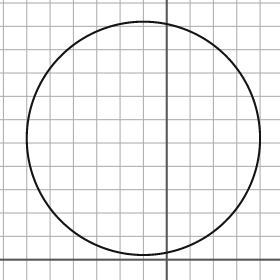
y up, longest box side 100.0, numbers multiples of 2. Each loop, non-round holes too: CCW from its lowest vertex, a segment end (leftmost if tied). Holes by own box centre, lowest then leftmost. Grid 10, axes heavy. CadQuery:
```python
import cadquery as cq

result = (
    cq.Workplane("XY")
    .moveTo(-10.0, 52.0)
    .circle(50.0)
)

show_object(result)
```